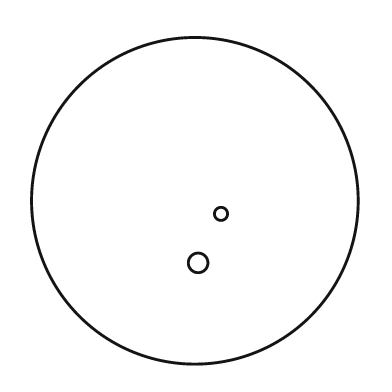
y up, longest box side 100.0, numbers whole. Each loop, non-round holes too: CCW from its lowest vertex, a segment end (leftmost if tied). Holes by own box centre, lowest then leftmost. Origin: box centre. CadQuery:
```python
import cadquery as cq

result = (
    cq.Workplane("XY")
    .moveTo(0.0, 0.0)
    .circle(50.0)
    .moveTo(1.0, -19.0)
    .circle(3.0)
    .moveTo(8.0, -4.0)
    .circle(2.0)
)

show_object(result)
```